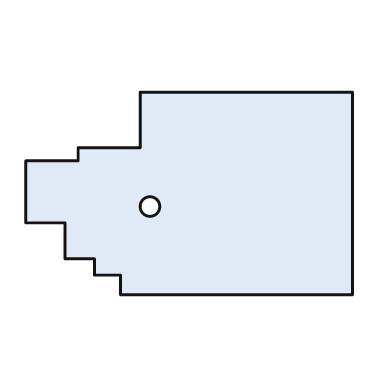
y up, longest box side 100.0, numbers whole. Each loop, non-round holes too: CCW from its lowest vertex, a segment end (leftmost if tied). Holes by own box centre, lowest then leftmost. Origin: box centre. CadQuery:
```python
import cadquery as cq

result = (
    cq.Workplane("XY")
    .moveTo(-21.0, -31.0)
    .lineTo(50.0, -31.0)
    .lineTo(50.0, 31.0)
    .lineTo(-15.0, 31.0)
    .lineTo(-15.0, 14.0)
    .lineTo(-34.0, 14.0)
    .lineTo(-34.0, 10.0)
    .lineTo(-50.0, 10.0)
    .lineTo(-50.0, -9.0)
    .lineTo(-38.0, -9.0)
    .lineTo(-38.0, -20.0)
    .lineTo(-29.0, -20.0)
    .lineTo(-29.0, -25.0)
    .lineTo(-21.0, -25.0)
    .close()
    .moveTo(-12.0, -4.0)
    .circle(3.0)
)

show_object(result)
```